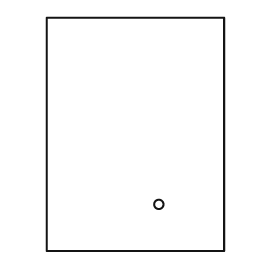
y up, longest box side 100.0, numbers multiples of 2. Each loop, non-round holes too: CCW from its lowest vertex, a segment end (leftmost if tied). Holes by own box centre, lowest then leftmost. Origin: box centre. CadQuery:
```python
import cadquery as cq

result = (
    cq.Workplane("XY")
    .moveTo(-38.0, -50.0)
    .lineTo(38.0, -50.0)
    .lineTo(38.0, 50.0)
    .lineTo(-38.0, 50.0)
    .close()
    .moveTo(10.0, -30.0)
    .circle(2.0)
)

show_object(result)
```